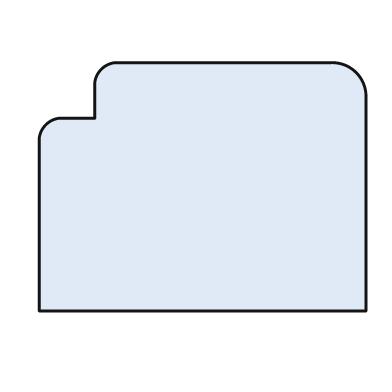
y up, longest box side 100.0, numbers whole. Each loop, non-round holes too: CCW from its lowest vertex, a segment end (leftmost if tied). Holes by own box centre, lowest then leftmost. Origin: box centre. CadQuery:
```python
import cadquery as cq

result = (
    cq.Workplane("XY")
    .moveTo(-50.0, -38.0)
    .lineTo(50.0, -38.0)
    .lineTo(50.0, 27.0)
    .threePointArc((47.0, 35.0), (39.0, 38.0))
    .lineTo(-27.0, 38.0)
    .threePointArc((-31.0, 36.0), (-33.0, 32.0))
    .lineTo(-33.0, 21.0)
    .lineTo(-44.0, 21.0)
    .threePointArc((-48.0, 19.0), (-50.0, 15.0))
    .close()
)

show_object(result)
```